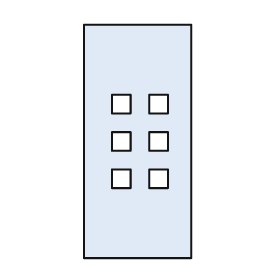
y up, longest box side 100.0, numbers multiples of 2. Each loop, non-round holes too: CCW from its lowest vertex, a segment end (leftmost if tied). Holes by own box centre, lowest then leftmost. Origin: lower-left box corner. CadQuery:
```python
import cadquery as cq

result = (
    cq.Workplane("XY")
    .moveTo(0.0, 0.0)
    .lineTo(46.0, 0.0)
    .lineTo(46.0, 100.0)
    .lineTo(0.0, 100.0)
    .close()
    .moveTo(12.0, 30.0)
    .lineTo(20.0, 30.0)
    .lineTo(20.0, 38.0)
    .lineTo(12.0, 38.0)
    .close()
    .moveTo(28.0, 30.0)
    .lineTo(36.0, 30.0)
    .lineTo(36.0, 38.0)
    .lineTo(28.0, 38.0)
    .close()
    .moveTo(12.0, 46.0)
    .lineTo(20.0, 46.0)
    .lineTo(20.0, 54.0)
    .lineTo(12.0, 54.0)
    .close()
    .moveTo(28.0, 46.0)
    .lineTo(36.0, 46.0)
    .lineTo(36.0, 54.0)
    .lineTo(28.0, 54.0)
    .close()
    .moveTo(12.0, 62.0)
    .lineTo(20.0, 62.0)
    .lineTo(20.0, 70.0)
    .lineTo(12.0, 70.0)
    .close()
    .moveTo(28.0, 62.0)
    .lineTo(36.0, 62.0)
    .lineTo(36.0, 70.0)
    .lineTo(28.0, 70.0)
    .close()
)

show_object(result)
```